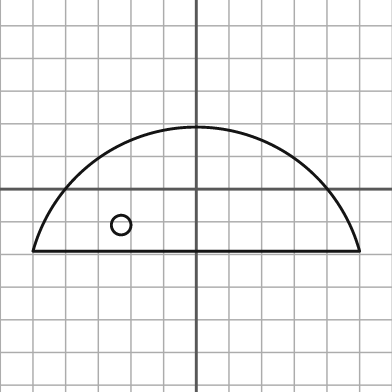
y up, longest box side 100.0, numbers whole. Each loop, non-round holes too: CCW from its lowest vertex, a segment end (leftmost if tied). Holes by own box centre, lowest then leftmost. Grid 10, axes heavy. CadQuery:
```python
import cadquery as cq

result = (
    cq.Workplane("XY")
    .moveTo(-50.0, -19.0)
    .lineTo(50.0, -19.0)
    .threePointArc((0.0, 19.0), (-50.0, -19.0))
    .close()
    .moveTo(-23.0, -11.0)
    .circle(3.0)
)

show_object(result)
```